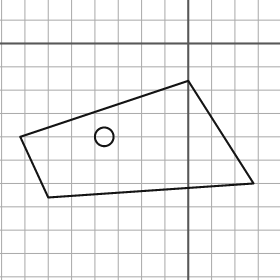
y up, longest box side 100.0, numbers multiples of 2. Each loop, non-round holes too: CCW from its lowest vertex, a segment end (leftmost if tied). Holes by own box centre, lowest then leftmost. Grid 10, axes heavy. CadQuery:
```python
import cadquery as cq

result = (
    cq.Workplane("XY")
    .moveTo(-60.0, -66.0)
    .lineTo(28.0, -60.0)
    .lineTo(0.0, -16.0)
    .lineTo(-72.0, -40.0)
    .close()
    .moveTo(-36.0, -40.0)
    .circle(4.0)
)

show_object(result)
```